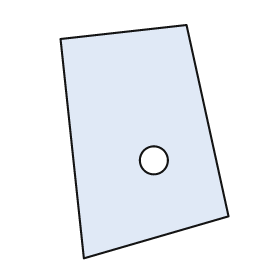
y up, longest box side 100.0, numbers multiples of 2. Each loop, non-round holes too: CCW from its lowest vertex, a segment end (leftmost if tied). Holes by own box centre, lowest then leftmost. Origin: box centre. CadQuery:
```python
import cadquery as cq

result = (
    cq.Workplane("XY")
    .moveTo(-26.0, -50.0)
    .lineTo(36.0, -32.0)
    .lineTo(18.0, 50.0)
    .lineTo(-36.0, 44.0)
    .close()
    .moveTo(4.0, -8.0)
    .circle(6.0)
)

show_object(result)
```